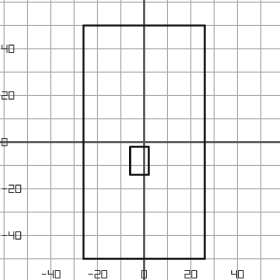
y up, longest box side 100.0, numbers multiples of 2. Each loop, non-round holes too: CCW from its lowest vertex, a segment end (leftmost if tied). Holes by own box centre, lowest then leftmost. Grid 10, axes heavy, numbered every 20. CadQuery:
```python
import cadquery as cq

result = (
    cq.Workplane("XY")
    .moveTo(-26.0, -50.0)
    .lineTo(26.0, -50.0)
    .lineTo(26.0, 50.0)
    .lineTo(-26.0, 50.0)
    .close()
    .moveTo(-6.0, -14.0)
    .lineTo(2.0, -14.0)
    .lineTo(2.0, -2.0)
    .lineTo(-6.0, -2.0)
    .close()
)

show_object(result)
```